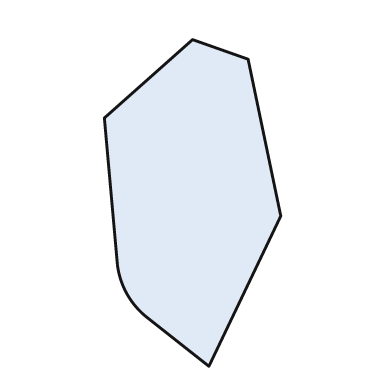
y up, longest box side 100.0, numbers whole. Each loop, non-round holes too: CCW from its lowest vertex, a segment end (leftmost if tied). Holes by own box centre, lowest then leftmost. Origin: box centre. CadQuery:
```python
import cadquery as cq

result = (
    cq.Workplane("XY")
    .moveTo(5.0, -50.0)
    .lineTo(27.0, -4.0)
    .lineTo(17.0, 44.0)
    .lineTo(0.0, 50.0)
    .lineTo(-27.0, 26.0)
    .lineTo(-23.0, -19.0)
    .threePointArc((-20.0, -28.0), (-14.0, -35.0))
    .close()
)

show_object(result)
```